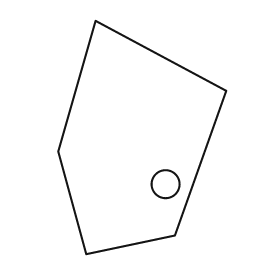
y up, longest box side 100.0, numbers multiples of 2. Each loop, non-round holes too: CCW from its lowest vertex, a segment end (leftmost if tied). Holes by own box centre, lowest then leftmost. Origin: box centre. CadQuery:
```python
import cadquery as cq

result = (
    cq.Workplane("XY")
    .moveTo(-24.0, -50.0)
    .lineTo(14.0, -42.0)
    .lineTo(36.0, 20.0)
    .lineTo(-20.0, 50.0)
    .lineTo(-36.0, -6.0)
    .close()
    .moveTo(10.0, -20.0)
    .circle(6.0)
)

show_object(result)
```